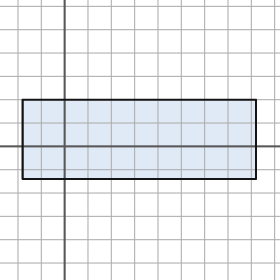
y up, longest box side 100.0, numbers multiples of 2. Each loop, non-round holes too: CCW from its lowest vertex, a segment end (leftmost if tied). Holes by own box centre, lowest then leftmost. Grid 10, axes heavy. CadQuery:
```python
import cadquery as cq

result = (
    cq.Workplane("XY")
    .moveTo(-18.0, -14.0)
    .lineTo(82.0, -14.0)
    .lineTo(82.0, 20.0)
    .lineTo(-18.0, 20.0)
    .close()
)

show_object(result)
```